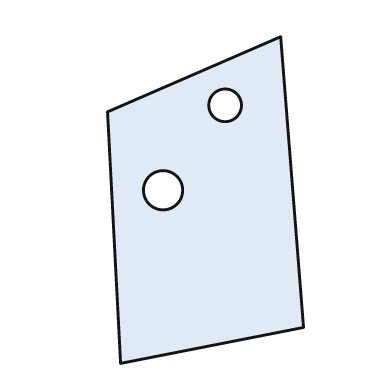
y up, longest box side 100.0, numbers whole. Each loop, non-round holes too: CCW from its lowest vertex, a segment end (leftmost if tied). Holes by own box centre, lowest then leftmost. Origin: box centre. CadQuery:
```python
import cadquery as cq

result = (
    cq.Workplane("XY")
    .moveTo(-26.0, -50.0)
    .lineTo(30.0, -39.0)
    .lineTo(23.0, 50.0)
    .lineTo(-30.0, 27.0)
    .close()
    .moveTo(-13.0, 3.0)
    .circle(6.0)
    .moveTo(6.0, 29.0)
    .circle(5.0)
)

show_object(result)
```